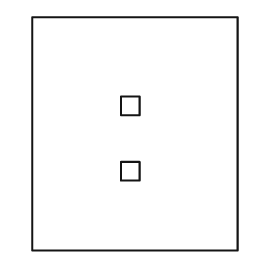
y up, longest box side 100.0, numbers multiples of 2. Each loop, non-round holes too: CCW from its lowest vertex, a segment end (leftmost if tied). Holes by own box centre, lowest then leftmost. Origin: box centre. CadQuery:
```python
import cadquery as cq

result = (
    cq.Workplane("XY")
    .moveTo(-44.0, -50.0)
    .lineTo(44.0, -50.0)
    .lineTo(44.0, 50.0)
    .lineTo(-44.0, 50.0)
    .close()
    .moveTo(-6.0, -20.0)
    .lineTo(2.0, -20.0)
    .lineTo(2.0, -12.0)
    .lineTo(-6.0, -12.0)
    .close()
    .moveTo(-6.0, 8.0)
    .lineTo(2.0, 8.0)
    .lineTo(2.0, 16.0)
    .lineTo(-6.0, 16.0)
    .close()
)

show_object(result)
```